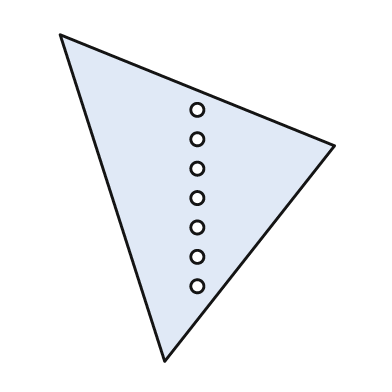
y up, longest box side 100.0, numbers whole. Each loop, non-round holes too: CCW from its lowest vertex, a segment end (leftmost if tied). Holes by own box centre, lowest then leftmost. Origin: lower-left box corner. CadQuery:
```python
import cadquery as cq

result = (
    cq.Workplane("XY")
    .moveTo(32.0, 0.0)
    .lineTo(84.0, 66.0)
    .lineTo(0.0, 100.0)
    .close()
    .moveTo(42.0, 23.0)
    .circle(2.0)
    .moveTo(42.0, 32.0)
    .circle(2.0)
    .moveTo(42.0, 41.0)
    .circle(2.0)
    .moveTo(42.0, 50.0)
    .circle(2.0)
    .moveTo(42.0, 59.0)
    .circle(2.0)
    .moveTo(42.0, 68.0)
    .circle(2.0)
    .moveTo(42.0, 77.0)
    .circle(2.0)
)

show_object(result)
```